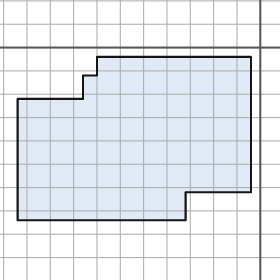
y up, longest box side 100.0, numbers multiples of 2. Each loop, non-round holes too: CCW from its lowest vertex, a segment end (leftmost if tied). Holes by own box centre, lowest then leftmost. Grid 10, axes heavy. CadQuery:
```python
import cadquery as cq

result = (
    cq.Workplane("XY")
    .moveTo(-104.0, -74.0)
    .lineTo(-32.0, -74.0)
    .lineTo(-32.0, -62.0)
    .lineTo(-4.0, -62.0)
    .lineTo(-4.0, -4.0)
    .lineTo(-70.0, -4.0)
    .lineTo(-70.0, -12.0)
    .lineTo(-76.0, -12.0)
    .lineTo(-76.0, -22.0)
    .lineTo(-104.0, -22.0)
    .close()
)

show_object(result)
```